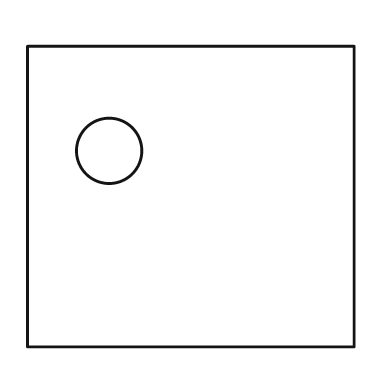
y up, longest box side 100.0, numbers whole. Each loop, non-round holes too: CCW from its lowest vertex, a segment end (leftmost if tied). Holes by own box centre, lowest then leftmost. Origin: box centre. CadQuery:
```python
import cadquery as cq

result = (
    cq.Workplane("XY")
    .moveTo(-50.0, -46.0)
    .lineTo(50.0, -46.0)
    .lineTo(50.0, 46.0)
    .lineTo(-50.0, 46.0)
    .close()
    .moveTo(-25.0, 14.0)
    .circle(10.0)
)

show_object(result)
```